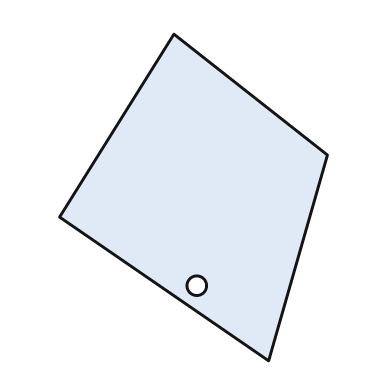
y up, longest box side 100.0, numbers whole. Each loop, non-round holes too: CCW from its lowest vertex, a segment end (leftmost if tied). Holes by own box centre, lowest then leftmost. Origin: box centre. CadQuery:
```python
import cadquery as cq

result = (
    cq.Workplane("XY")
    .moveTo(23.0, -50.0)
    .lineTo(41.0, 13.0)
    .lineTo(-6.0, 50.0)
    .lineTo(-41.0, -6.0)
    .close()
    .moveTo(1.0, -27.0)
    .circle(3.0)
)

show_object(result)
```